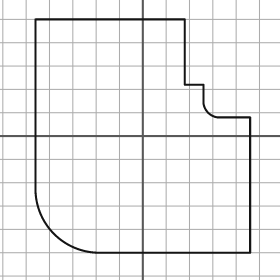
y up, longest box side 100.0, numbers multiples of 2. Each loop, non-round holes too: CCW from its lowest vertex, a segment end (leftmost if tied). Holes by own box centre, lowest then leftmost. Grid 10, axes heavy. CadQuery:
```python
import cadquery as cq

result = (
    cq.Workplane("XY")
    .moveTo(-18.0, -50.0)
    .lineTo(46.0, -50.0)
    .lineTo(46.0, 8.0)
    .lineTo(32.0, 8.0)
    .threePointArc((28.0, 10.0), (26.0, 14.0))
    .lineTo(26.0, 22.0)
    .lineTo(18.0, 22.0)
    .lineTo(18.0, 50.0)
    .lineTo(-46.0, 50.0)
    .lineTo(-46.0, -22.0)
    .threePointArc((-38.0, -42.0), (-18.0, -50.0))
    .close()
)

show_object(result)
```